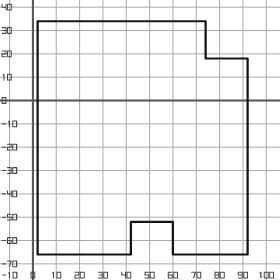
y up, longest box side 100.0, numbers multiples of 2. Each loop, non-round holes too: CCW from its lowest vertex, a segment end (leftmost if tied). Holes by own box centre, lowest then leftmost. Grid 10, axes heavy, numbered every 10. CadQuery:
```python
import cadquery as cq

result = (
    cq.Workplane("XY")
    .moveTo(2.0, -66.0)
    .lineTo(42.0, -66.0)
    .lineTo(42.0, -52.0)
    .lineTo(60.0, -52.0)
    .lineTo(60.0, -66.0)
    .lineTo(92.0, -66.0)
    .lineTo(92.0, 18.0)
    .lineTo(74.0, 18.0)
    .lineTo(74.0, 34.0)
    .lineTo(2.0, 34.0)
    .close()
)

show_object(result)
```